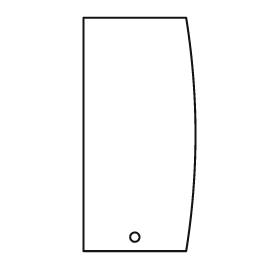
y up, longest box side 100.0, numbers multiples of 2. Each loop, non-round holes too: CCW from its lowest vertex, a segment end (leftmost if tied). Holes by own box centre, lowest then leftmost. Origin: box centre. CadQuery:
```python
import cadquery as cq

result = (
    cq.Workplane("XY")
    .moveTo(-24.0, -50.0)
    .lineTo(20.0, -50.0)
    .threePointArc((24.0, 0.0), (20.0, 50.0))
    .lineTo(-24.0, 50.0)
    .close()
    .moveTo(-2.0, -44.0)
    .circle(2.0)
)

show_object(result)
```